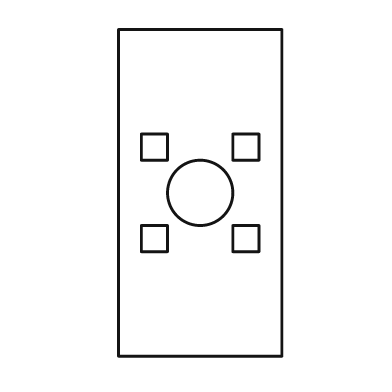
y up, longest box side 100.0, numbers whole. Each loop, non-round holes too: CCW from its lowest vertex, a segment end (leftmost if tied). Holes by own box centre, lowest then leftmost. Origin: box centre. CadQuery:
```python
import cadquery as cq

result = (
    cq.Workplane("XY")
    .moveTo(-25.0, -50.0)
    .lineTo(25.0, -50.0)
    .lineTo(25.0, 50.0)
    .lineTo(-25.0, 50.0)
    .close()
    .moveTo(-18.0, -18.0)
    .lineTo(-10.0, -18.0)
    .lineTo(-10.0, -10.0)
    .lineTo(-18.0, -10.0)
    .close()
    .moveTo(10.0, -18.0)
    .lineTo(18.0, -18.0)
    .lineTo(18.0, -10.0)
    .lineTo(10.0, -10.0)
    .close()
    .moveTo(0.0, 0.0)
    .circle(10.0)
    .moveTo(-18.0, 10.0)
    .lineTo(-10.0, 10.0)
    .lineTo(-10.0, 18.0)
    .lineTo(-18.0, 18.0)
    .close()
    .moveTo(10.0, 10.0)
    .lineTo(18.0, 10.0)
    .lineTo(18.0, 18.0)
    .lineTo(10.0, 18.0)
    .close()
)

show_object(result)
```